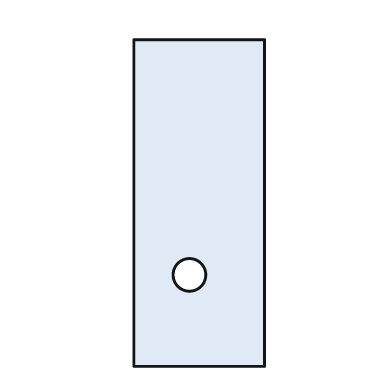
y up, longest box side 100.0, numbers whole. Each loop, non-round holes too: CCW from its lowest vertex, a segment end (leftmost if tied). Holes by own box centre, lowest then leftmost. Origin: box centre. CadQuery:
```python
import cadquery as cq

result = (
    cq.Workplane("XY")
    .moveTo(-20.0, -50.0)
    .lineTo(20.0, -50.0)
    .lineTo(20.0, 50.0)
    .lineTo(-20.0, 50.0)
    .close()
    .moveTo(-3.0, -22.0)
    .circle(5.0)
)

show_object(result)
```